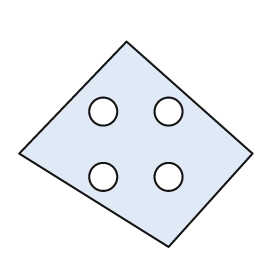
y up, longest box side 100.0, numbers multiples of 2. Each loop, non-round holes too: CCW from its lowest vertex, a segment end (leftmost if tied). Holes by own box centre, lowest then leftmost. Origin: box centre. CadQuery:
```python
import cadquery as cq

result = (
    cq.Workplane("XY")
    .moveTo(14.0, -44.0)
    .lineTo(50.0, -4.0)
    .lineTo(-4.0, 44.0)
    .lineTo(-50.0, -4.0)
    .close()
    .moveTo(-14.0, -14.0)
    .circle(6.0)
    .moveTo(14.0, -14.0)
    .circle(6.0)
    .moveTo(-14.0, 14.0)
    .circle(6.0)
    .moveTo(14.0, 14.0)
    .circle(6.0)
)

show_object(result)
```